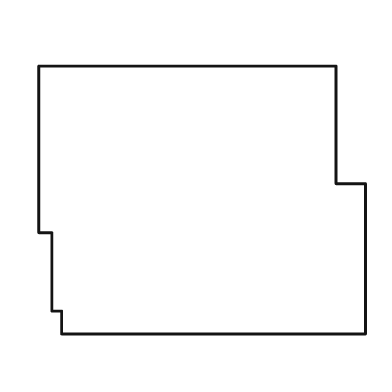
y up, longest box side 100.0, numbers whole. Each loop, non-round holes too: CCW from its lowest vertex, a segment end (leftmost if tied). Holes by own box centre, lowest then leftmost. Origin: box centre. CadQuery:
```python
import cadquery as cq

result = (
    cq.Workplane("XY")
    .moveTo(-43.0, -41.0)
    .lineTo(50.0, -41.0)
    .lineTo(50.0, 5.0)
    .lineTo(41.0, 5.0)
    .lineTo(41.0, 41.0)
    .lineTo(-50.0, 41.0)
    .lineTo(-50.0, -10.0)
    .lineTo(-46.0, -10.0)
    .lineTo(-46.0, -34.0)
    .lineTo(-43.0, -34.0)
    .close()
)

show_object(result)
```